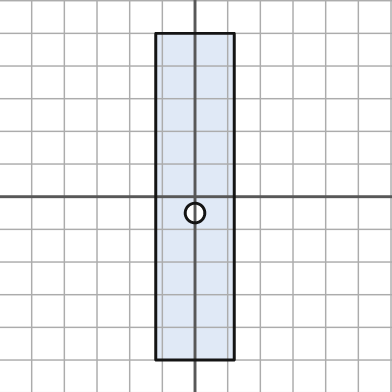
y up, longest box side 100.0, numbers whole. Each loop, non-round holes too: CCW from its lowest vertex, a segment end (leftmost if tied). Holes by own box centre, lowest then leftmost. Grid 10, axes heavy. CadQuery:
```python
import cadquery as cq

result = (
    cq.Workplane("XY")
    .moveTo(-12.0, -50.0)
    .lineTo(12.0, -50.0)
    .lineTo(12.0, 50.0)
    .lineTo(-12.0, 50.0)
    .close()
    .moveTo(0.0, -5.0)
    .circle(3.0)
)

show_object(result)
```